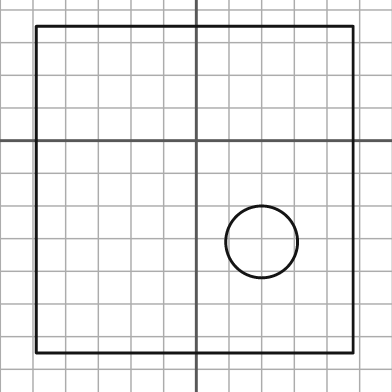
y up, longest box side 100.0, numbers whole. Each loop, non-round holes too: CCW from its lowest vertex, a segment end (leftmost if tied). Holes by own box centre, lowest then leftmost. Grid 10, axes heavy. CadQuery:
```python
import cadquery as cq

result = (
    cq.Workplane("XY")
    .moveTo(-49.0, -65.0)
    .lineTo(48.0, -65.0)
    .lineTo(48.0, 35.0)
    .lineTo(-49.0, 35.0)
    .close()
    .moveTo(20.0, -31.0)
    .circle(11.0)
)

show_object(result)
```